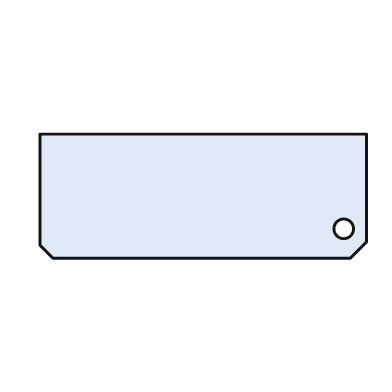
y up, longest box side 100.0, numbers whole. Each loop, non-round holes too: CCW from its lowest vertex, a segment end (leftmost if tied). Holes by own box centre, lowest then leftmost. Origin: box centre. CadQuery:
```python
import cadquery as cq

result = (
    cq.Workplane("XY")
    .moveTo(-46.0, -19.0)
    .lineTo(45.0, -19.0)
    .lineTo(50.0, -14.0)
    .lineTo(50.0, 19.0)
    .lineTo(-50.0, 19.0)
    .lineTo(-50.0, -15.0)
    .close()
    .moveTo(43.0, -10.0)
    .circle(3.0)
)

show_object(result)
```